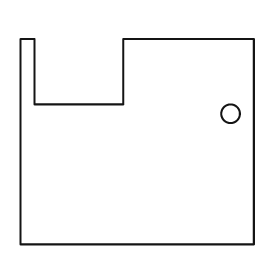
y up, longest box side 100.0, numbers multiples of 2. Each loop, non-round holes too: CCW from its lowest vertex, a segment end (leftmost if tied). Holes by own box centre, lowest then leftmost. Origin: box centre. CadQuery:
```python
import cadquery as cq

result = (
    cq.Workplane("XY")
    .moveTo(-50.0, -44.0)
    .lineTo(50.0, -44.0)
    .lineTo(50.0, 44.0)
    .lineTo(-6.0, 44.0)
    .lineTo(-6.0, 16.0)
    .lineTo(-44.0, 16.0)
    .lineTo(-44.0, 44.0)
    .lineTo(-50.0, 44.0)
    .close()
    .moveTo(40.0, 12.0)
    .circle(4.0)
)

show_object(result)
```